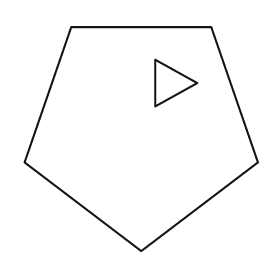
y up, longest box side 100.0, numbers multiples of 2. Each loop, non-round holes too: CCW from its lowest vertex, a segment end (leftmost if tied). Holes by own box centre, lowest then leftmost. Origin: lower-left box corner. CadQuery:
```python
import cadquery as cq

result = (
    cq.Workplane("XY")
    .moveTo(50.0, 0.0)
    .lineTo(100.0, 38.0)
    .lineTo(80.0, 96.0)
    .lineTo(20.0, 96.0)
    .lineTo(0.0, 38.0)
    .close()
    .moveTo(56.0, 62.0)
    .lineTo(74.0, 72.0)
    .lineTo(56.0, 82.0)
    .close()
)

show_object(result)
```